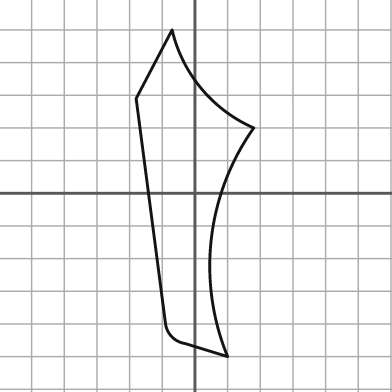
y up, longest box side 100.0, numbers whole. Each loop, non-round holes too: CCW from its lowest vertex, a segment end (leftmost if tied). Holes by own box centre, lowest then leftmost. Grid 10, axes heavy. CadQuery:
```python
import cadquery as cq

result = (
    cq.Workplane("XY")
    .moveTo(10.0, -50.0)
    .threePointArc((5.0, -14.0), (18.0, 20.0))
    .threePointArc((2.0, 32.0), (-7.0, 50.0))
    .lineTo(-18.0, 29.0)
    .lineTo(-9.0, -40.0)
    .threePointArc((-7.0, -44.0), (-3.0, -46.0))
    .close()
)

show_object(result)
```